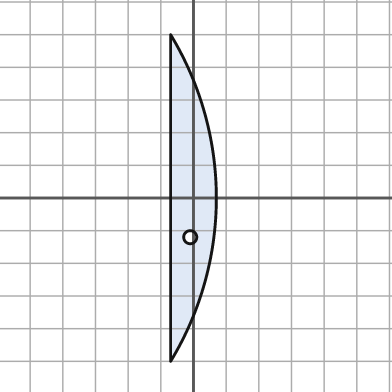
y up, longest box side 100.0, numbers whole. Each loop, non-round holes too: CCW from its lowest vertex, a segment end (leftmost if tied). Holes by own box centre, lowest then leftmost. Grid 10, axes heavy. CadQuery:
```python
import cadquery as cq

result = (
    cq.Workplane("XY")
    .moveTo(-7.0, -50.0)
    .threePointArc((7.0, 0.0), (-7.0, 50.0))
    .close()
    .moveTo(-1.0, -12.0)
    .circle(2.0)
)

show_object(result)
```